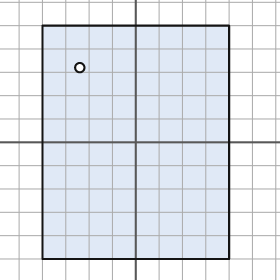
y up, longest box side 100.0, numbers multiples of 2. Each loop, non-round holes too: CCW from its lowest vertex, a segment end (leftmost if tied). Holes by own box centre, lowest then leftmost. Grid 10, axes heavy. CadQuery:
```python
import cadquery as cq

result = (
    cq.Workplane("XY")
    .moveTo(-40.0, -50.0)
    .lineTo(40.0, -50.0)
    .lineTo(40.0, 50.0)
    .lineTo(-40.0, 50.0)
    .close()
    .moveTo(-24.0, 32.0)
    .circle(2.0)
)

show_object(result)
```